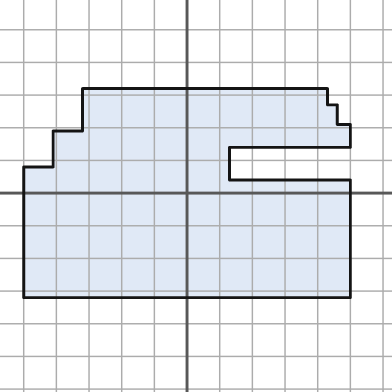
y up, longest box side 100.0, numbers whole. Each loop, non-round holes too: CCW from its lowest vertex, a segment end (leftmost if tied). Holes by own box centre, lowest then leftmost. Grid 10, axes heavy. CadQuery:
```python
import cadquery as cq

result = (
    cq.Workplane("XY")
    .moveTo(-50.0, -32.0)
    .lineTo(50.0, -32.0)
    .lineTo(50.0, 4.0)
    .lineTo(13.0, 4.0)
    .lineTo(13.0, 14.0)
    .lineTo(50.0, 14.0)
    .lineTo(50.0, 21.0)
    .lineTo(46.0, 21.0)
    .lineTo(46.0, 27.0)
    .lineTo(43.0, 27.0)
    .lineTo(43.0, 32.0)
    .lineTo(-32.0, 32.0)
    .lineTo(-32.0, 19.0)
    .lineTo(-41.0, 19.0)
    .lineTo(-41.0, 8.0)
    .lineTo(-50.0, 8.0)
    .close()
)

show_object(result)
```